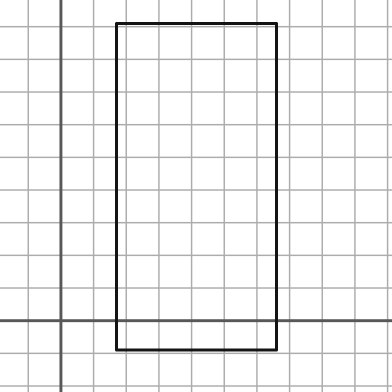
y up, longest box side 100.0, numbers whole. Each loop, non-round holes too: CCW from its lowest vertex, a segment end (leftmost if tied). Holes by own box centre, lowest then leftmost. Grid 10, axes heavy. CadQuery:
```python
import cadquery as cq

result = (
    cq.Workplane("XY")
    .moveTo(17.0, -9.0)
    .lineTo(66.0, -9.0)
    .lineTo(66.0, 91.0)
    .lineTo(17.0, 91.0)
    .close()
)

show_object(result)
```